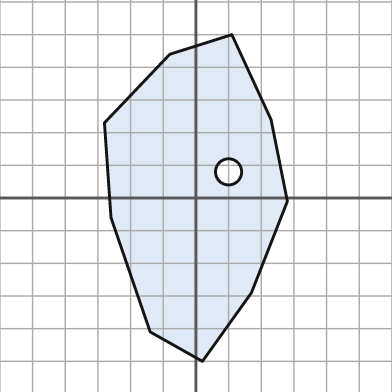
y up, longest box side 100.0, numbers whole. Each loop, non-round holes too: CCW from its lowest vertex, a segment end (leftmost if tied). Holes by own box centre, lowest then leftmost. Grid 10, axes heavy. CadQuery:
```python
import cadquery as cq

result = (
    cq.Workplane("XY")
    .moveTo(2.0, -50.0)
    .lineTo(17.0, -29.0)
    .lineTo(28.0, -1.0)
    .lineTo(23.0, 24.0)
    .lineTo(11.0, 50.0)
    .lineTo(-8.0, 44.0)
    .lineTo(-28.0, 23.0)
    .lineTo(-26.0, -6.0)
    .lineTo(-14.0, -41.0)
    .close()
    .moveTo(10.0, 8.0)
    .circle(4.0)
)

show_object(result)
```